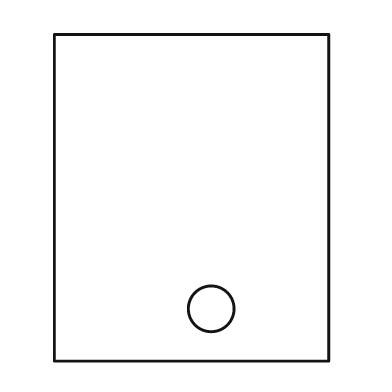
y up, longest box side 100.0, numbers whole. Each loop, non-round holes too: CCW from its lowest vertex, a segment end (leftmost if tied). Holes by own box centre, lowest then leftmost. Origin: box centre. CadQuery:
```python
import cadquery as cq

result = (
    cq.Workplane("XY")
    .moveTo(-42.0, -50.0)
    .lineTo(42.0, -50.0)
    .lineTo(42.0, 50.0)
    .lineTo(-42.0, 50.0)
    .close()
    .moveTo(6.0, -34.0)
    .circle(7.0)
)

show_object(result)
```